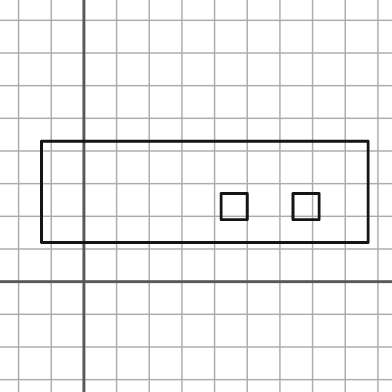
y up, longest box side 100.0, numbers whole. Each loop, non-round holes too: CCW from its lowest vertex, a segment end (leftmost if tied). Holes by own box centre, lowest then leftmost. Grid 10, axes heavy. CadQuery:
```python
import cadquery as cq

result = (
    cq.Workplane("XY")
    .moveTo(-13.0, 12.0)
    .lineTo(87.0, 12.0)
    .lineTo(87.0, 43.0)
    .lineTo(-13.0, 43.0)
    .close()
    .moveTo(42.0, 19.0)
    .lineTo(50.0, 19.0)
    .lineTo(50.0, 27.0)
    .lineTo(42.0, 27.0)
    .close()
    .moveTo(64.0, 19.0)
    .lineTo(72.0, 19.0)
    .lineTo(72.0, 27.0)
    .lineTo(64.0, 27.0)
    .close()
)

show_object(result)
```